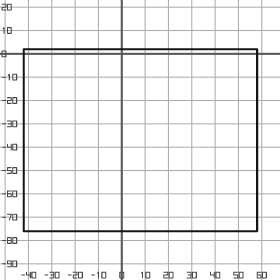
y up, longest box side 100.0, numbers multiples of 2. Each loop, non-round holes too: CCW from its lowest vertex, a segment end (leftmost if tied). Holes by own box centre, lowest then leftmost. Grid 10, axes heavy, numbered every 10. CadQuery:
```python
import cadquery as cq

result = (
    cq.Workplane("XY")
    .moveTo(-42.0, -76.0)
    .lineTo(58.0, -76.0)
    .lineTo(58.0, 2.0)
    .lineTo(-42.0, 2.0)
    .close()
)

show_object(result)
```